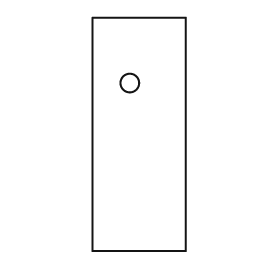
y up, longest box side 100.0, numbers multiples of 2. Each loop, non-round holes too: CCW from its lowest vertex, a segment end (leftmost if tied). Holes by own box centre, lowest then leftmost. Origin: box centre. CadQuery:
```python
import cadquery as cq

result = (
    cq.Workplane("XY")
    .moveTo(-20.0, -50.0)
    .lineTo(20.0, -50.0)
    .lineTo(20.0, 50.0)
    .lineTo(-20.0, 50.0)
    .close()
    .moveTo(-4.0, 22.0)
    .circle(4.0)
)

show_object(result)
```